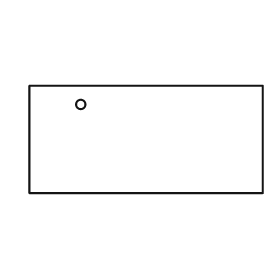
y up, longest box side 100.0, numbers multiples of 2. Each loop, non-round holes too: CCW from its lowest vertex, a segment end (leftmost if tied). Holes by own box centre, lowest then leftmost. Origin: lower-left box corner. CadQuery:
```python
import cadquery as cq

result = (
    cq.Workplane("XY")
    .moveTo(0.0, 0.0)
    .lineTo(100.0, 0.0)
    .lineTo(100.0, 46.0)
    .lineTo(0.0, 46.0)
    .close()
    .moveTo(22.0, 38.0)
    .circle(2.0)
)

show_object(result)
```